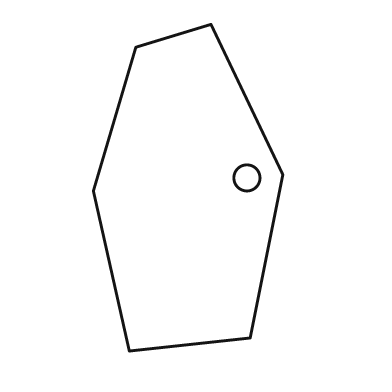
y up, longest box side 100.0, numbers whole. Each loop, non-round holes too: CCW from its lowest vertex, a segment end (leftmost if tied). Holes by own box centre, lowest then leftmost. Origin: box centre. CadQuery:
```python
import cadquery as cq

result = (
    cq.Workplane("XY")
    .moveTo(-18.0, -50.0)
    .lineTo(19.0, -46.0)
    .lineTo(29.0, 4.0)
    .lineTo(7.0, 50.0)
    .lineTo(-16.0, 43.0)
    .lineTo(-29.0, -1.0)
    .close()
    .moveTo(18.0, 3.0)
    .circle(4.0)
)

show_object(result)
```